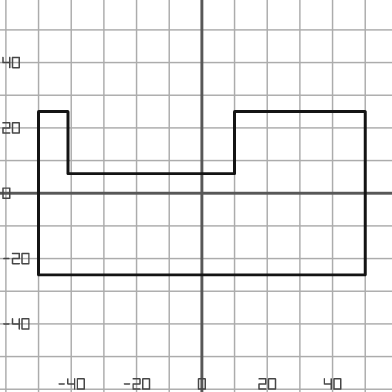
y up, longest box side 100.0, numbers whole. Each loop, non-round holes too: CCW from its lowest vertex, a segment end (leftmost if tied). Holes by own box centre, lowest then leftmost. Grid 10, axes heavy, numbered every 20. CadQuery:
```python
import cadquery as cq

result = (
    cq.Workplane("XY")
    .moveTo(-50.0, -25.0)
    .lineTo(50.0, -25.0)
    .lineTo(50.0, 25.0)
    .lineTo(10.0, 25.0)
    .lineTo(10.0, 6.0)
    .lineTo(-41.0, 6.0)
    .lineTo(-41.0, 25.0)
    .lineTo(-50.0, 25.0)
    .close()
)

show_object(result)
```